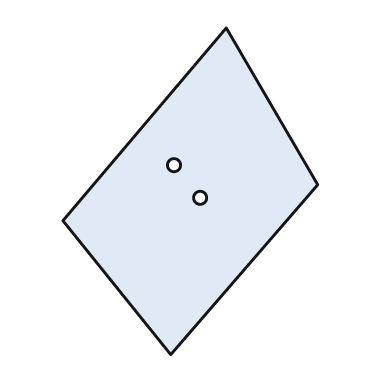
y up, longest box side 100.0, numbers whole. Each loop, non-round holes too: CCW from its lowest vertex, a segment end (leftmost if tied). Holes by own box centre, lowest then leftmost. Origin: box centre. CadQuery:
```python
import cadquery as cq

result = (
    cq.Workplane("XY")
    .moveTo(-6.0, -50.0)
    .lineTo(39.0, 2.0)
    .lineTo(11.0, 50.0)
    .lineTo(-39.0, -9.0)
    .close()
    .moveTo(3.0, -2.0)
    .circle(2.0)
    .moveTo(-5.0, 8.0)
    .circle(2.0)
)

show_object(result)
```